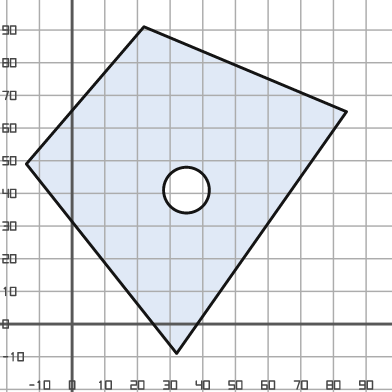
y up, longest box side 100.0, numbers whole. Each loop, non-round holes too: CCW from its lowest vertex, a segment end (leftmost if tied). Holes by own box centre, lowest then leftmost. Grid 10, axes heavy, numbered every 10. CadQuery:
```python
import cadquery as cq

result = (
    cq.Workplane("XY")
    .moveTo(32.0, -9.0)
    .lineTo(84.0, 65.0)
    .lineTo(22.0, 91.0)
    .lineTo(-14.0, 49.0)
    .close()
    .moveTo(35.0, 41.0)
    .circle(7.0)
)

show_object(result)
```